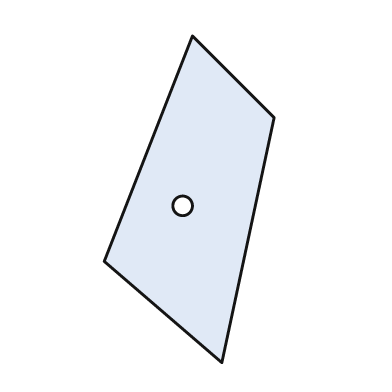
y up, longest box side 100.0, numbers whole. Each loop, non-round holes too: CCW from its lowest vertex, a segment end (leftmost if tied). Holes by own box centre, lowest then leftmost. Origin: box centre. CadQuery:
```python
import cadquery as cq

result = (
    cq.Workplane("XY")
    .moveTo(10.0, -50.0)
    .lineTo(26.0, 25.0)
    .lineTo(1.0, 50.0)
    .lineTo(-26.0, -19.0)
    .close()
    .moveTo(-2.0, -2.0)
    .circle(3.0)
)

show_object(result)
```